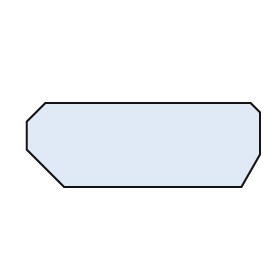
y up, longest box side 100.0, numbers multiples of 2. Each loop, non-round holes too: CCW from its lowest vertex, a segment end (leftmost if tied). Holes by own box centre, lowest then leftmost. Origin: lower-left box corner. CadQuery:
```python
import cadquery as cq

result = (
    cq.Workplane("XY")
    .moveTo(16.0, 0.0)
    .lineTo(92.0, 0.0)
    .lineTo(100.0, 14.0)
    .lineTo(100.0, 32.0)
    .lineTo(96.0, 36.0)
    .lineTo(8.0, 36.0)
    .lineTo(0.0, 28.0)
    .lineTo(0.0, 16.0)
    .close()
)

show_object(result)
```